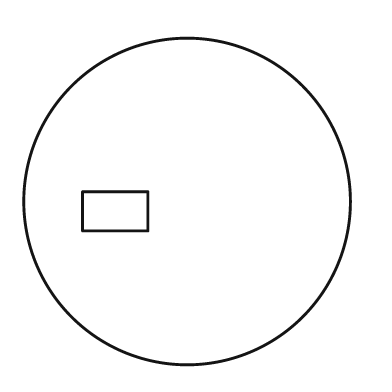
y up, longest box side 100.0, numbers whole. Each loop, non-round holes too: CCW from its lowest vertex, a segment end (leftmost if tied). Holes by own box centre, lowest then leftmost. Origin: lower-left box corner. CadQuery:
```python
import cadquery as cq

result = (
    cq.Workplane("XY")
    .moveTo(50.0, 50.0)
    .circle(50.0)
    .moveTo(18.0, 41.0)
    .lineTo(38.0, 41.0)
    .lineTo(38.0, 53.0)
    .lineTo(18.0, 53.0)
    .close()
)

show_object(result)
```